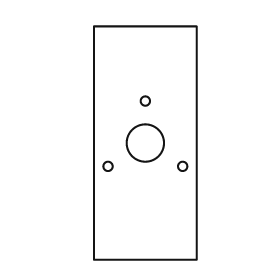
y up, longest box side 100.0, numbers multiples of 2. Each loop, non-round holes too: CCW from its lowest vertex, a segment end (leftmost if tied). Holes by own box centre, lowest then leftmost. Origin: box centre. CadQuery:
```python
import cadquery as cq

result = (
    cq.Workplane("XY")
    .moveTo(-22.0, -50.0)
    .lineTo(22.0, -50.0)
    .lineTo(22.0, 50.0)
    .lineTo(-22.0, 50.0)
    .close()
    .moveTo(-16.0, -10.0)
    .circle(2.0)
    .moveTo(16.0, -10.0)
    .circle(2.0)
    .moveTo(0.0, 0.0)
    .circle(8.0)
    .moveTo(0.0, 18.0)
    .circle(2.0)
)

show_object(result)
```